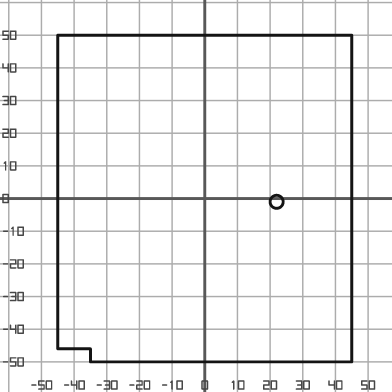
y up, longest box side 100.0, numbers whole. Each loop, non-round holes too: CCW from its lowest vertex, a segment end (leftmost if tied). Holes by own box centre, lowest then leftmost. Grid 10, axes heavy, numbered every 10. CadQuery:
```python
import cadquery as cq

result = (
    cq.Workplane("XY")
    .moveTo(-35.0, -50.0)
    .lineTo(45.0, -50.0)
    .lineTo(45.0, 50.0)
    .lineTo(-45.0, 50.0)
    .lineTo(-45.0, -46.0)
    .lineTo(-35.0, -46.0)
    .close()
    .moveTo(22.0, -1.0)
    .circle(2.0)
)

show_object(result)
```